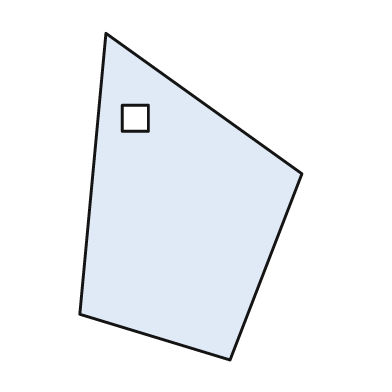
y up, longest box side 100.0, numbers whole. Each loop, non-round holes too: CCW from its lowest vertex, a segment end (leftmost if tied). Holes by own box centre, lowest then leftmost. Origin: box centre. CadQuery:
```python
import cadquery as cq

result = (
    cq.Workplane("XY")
    .moveTo(12.0, -50.0)
    .lineTo(34.0, 7.0)
    .lineTo(-26.0, 50.0)
    .lineTo(-34.0, -36.0)
    .close()
    .moveTo(-21.0, 20.0)
    .lineTo(-13.0, 20.0)
    .lineTo(-13.0, 28.0)
    .lineTo(-21.0, 28.0)
    .close()
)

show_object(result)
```